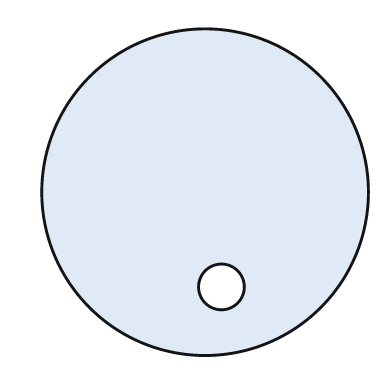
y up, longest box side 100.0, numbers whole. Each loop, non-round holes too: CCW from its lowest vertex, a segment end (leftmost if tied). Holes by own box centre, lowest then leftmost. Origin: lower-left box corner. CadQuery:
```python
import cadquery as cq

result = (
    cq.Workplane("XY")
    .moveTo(50.0, 50.0)
    .circle(50.0)
    .moveTo(55.0, 21.0)
    .circle(7.0)
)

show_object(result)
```